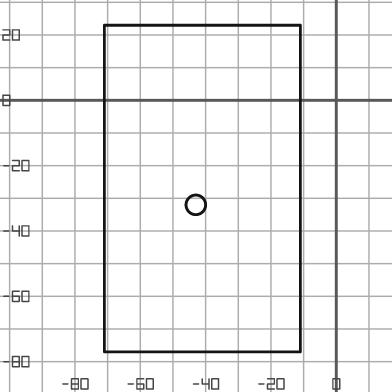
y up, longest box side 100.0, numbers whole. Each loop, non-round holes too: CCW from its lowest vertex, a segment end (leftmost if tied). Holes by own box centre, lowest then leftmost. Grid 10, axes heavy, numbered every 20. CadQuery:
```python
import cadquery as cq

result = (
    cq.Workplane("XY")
    .moveTo(-71.0, -77.0)
    .lineTo(-11.0, -77.0)
    .lineTo(-11.0, 23.0)
    .lineTo(-71.0, 23.0)
    .close()
    .moveTo(-43.0, -32.0)
    .circle(3.0)
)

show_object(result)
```